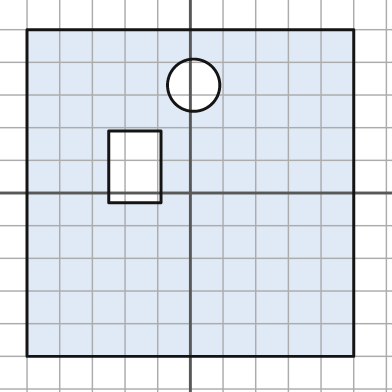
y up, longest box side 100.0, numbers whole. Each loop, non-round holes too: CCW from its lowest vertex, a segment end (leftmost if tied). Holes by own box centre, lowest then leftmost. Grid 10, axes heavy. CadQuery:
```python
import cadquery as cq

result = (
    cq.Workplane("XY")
    .moveTo(-50.0, -50.0)
    .lineTo(50.0, -50.0)
    .lineTo(50.0, 50.0)
    .lineTo(-50.0, 50.0)
    .close()
    .moveTo(-25.0, -3.0)
    .lineTo(-9.0, -3.0)
    .lineTo(-9.0, 19.0)
    .lineTo(-25.0, 19.0)
    .close()
    .moveTo(1.0, 33.0)
    .circle(8.0)
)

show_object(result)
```